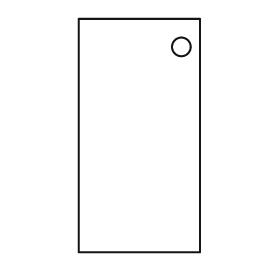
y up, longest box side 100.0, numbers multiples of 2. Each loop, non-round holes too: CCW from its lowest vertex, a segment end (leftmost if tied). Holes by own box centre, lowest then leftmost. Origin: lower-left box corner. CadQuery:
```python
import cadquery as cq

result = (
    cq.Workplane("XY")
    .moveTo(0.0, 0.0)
    .lineTo(52.0, 0.0)
    .lineTo(52.0, 100.0)
    .lineTo(0.0, 100.0)
    .close()
    .moveTo(44.0, 88.0)
    .circle(4.0)
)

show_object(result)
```